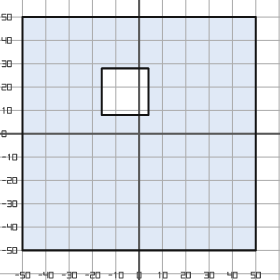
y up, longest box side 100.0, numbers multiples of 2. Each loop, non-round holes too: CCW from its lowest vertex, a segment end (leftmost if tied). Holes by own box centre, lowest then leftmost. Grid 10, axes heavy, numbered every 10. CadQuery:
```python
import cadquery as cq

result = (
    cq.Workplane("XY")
    .moveTo(-50.0, -50.0)
    .lineTo(50.0, -50.0)
    .lineTo(50.0, 50.0)
    .lineTo(-50.0, 50.0)
    .close()
    .moveTo(-16.0, 8.0)
    .lineTo(4.0, 8.0)
    .lineTo(4.0, 28.0)
    .lineTo(-16.0, 28.0)
    .close()
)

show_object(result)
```